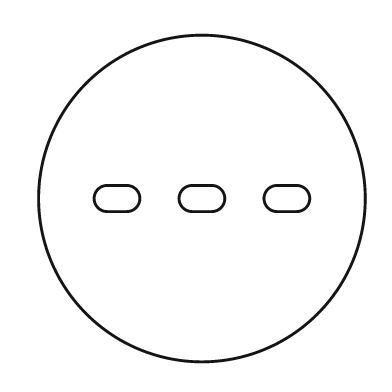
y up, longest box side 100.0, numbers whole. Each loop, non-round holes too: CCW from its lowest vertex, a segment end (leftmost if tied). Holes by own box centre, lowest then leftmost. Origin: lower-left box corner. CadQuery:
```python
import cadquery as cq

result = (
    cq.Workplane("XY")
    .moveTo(50.0, 50.0)
    .circle(50.0)
    .moveTo(21.0, 46.0)
    .lineTo(27.0, 46.0)
    .threePointArc((31.0, 50.0), (27.0, 54.0))
    .lineTo(21.0, 54.0)
    .threePointArc((17.0, 50.0), (21.0, 46.0))
    .close()
    .moveTo(47.0, 46.0)
    .lineTo(53.0, 46.0)
    .threePointArc((57.0, 50.0), (53.0, 54.0))
    .lineTo(47.0, 54.0)
    .threePointArc((43.0, 50.0), (47.0, 46.0))
    .close()
    .moveTo(73.0, 46.0)
    .lineTo(79.0, 46.0)
    .threePointArc((83.0, 50.0), (79.0, 54.0))
    .lineTo(73.0, 54.0)
    .threePointArc((69.0, 50.0), (73.0, 46.0))
    .close()
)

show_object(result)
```